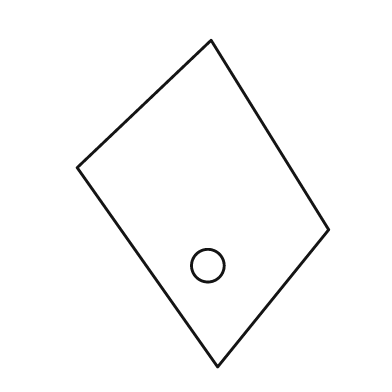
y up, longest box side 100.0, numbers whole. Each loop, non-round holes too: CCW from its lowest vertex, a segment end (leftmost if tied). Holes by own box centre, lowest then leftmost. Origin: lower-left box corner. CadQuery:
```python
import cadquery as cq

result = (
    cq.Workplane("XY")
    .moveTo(43.0, 0.0)
    .lineTo(77.0, 42.0)
    .lineTo(41.0, 100.0)
    .lineTo(0.0, 61.0)
    .close()
    .moveTo(40.0, 31.0)
    .circle(5.0)
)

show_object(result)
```